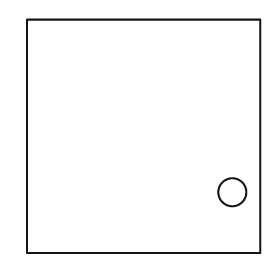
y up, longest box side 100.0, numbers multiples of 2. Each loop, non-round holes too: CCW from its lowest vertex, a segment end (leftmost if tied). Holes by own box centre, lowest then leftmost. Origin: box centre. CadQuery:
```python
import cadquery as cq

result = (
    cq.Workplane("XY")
    .moveTo(-50.0, -50.0)
    .lineTo(50.0, -50.0)
    .lineTo(50.0, 50.0)
    .lineTo(-50.0, 50.0)
    .close()
    .moveTo(38.0, -24.0)
    .circle(6.0)
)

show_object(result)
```